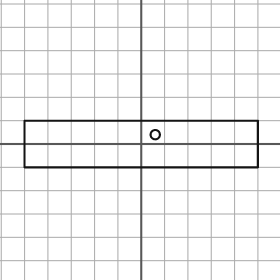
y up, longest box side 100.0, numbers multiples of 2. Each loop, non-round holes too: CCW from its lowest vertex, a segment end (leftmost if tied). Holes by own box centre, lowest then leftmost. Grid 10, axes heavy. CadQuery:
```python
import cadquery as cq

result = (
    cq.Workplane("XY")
    .moveTo(-50.0, -10.0)
    .lineTo(50.0, -10.0)
    .lineTo(50.0, 10.0)
    .lineTo(-50.0, 10.0)
    .close()
    .moveTo(6.0, 4.0)
    .circle(2.0)
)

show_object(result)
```